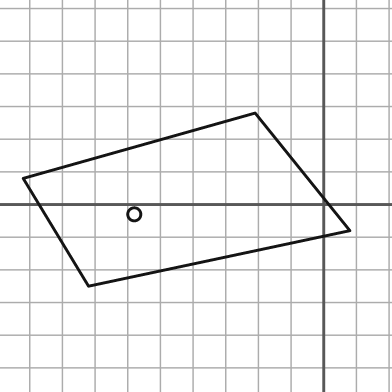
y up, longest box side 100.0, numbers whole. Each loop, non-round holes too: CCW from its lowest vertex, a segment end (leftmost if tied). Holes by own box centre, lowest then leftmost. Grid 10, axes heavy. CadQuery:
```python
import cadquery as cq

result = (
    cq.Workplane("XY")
    .moveTo(-72.0, -25.0)
    .lineTo(8.0, -8.0)
    .lineTo(-21.0, 28.0)
    .lineTo(-92.0, 8.0)
    .close()
    .moveTo(-58.0, -3.0)
    .circle(2.0)
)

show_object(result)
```